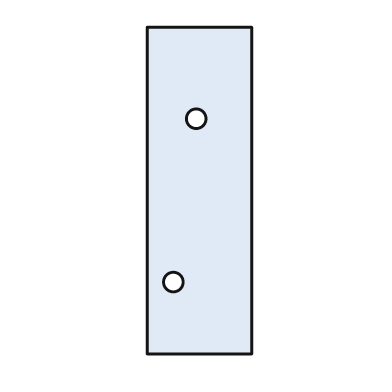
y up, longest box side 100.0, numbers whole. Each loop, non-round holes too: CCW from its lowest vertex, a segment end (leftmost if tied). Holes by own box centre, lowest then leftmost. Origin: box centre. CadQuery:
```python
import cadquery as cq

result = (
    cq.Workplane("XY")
    .moveTo(-16.0, -50.0)
    .lineTo(16.0, -50.0)
    .lineTo(16.0, 50.0)
    .lineTo(-16.0, 50.0)
    .close()
    .moveTo(-8.0, -28.0)
    .circle(3.0)
    .moveTo(-1.0, 22.0)
    .circle(3.0)
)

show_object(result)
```